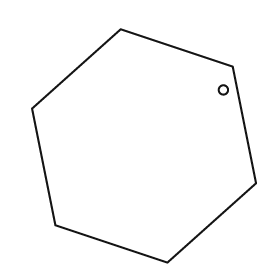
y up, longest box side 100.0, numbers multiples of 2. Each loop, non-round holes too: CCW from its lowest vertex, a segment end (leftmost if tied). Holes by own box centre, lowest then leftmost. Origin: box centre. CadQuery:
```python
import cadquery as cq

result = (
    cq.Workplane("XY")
    .moveTo(10.0, -50.0)
    .lineTo(48.0, -16.0)
    .lineTo(38.0, 34.0)
    .lineTo(-10.0, 50.0)
    .lineTo(-48.0, 16.0)
    .lineTo(-38.0, -34.0)
    .close()
    .moveTo(34.0, 24.0)
    .circle(2.0)
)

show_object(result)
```